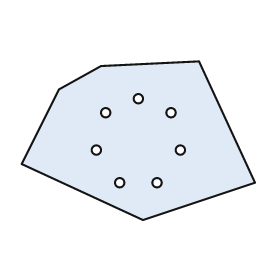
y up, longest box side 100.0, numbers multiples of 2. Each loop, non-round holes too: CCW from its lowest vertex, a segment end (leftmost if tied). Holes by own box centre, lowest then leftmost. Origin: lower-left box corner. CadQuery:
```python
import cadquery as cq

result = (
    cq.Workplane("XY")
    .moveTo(52.0, 0.0)
    .lineTo(100.0, 16.0)
    .lineTo(76.0, 68.0)
    .lineTo(34.0, 66.0)
    .lineTo(16.0, 56.0)
    .lineTo(0.0, 24.0)
    .close()
    .moveTo(42.0, 16.0)
    .circle(2.0)
    .moveTo(58.0, 16.0)
    .circle(2.0)
    .moveTo(32.0, 30.0)
    .circle(2.0)
    .moveTo(68.0, 30.0)
    .circle(2.0)
    .moveTo(36.0, 46.0)
    .circle(2.0)
    .moveTo(64.0, 46.0)
    .circle(2.0)
    .moveTo(50.0, 52.0)
    .circle(2.0)
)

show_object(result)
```